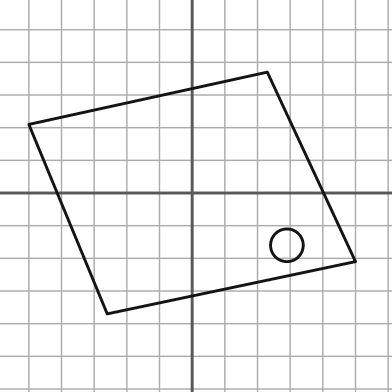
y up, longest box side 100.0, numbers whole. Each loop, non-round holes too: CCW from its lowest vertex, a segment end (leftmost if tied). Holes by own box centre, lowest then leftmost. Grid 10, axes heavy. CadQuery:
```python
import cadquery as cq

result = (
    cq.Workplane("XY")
    .moveTo(-26.0, -37.0)
    .lineTo(50.0, -21.0)
    .lineTo(23.0, 37.0)
    .lineTo(-50.0, 21.0)
    .close()
    .moveTo(29.0, -16.0)
    .circle(5.0)
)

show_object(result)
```